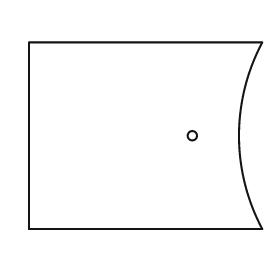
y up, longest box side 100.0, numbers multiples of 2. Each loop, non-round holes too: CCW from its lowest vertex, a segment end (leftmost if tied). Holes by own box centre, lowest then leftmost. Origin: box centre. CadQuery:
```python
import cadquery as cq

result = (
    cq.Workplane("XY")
    .moveTo(-50.0, -40.0)
    .lineTo(50.0, -40.0)
    .threePointArc((40.0, 0.0), (50.0, 40.0))
    .lineTo(-50.0, 40.0)
    .close()
    .moveTo(20.0, 0.0)
    .circle(2.0)
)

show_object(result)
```